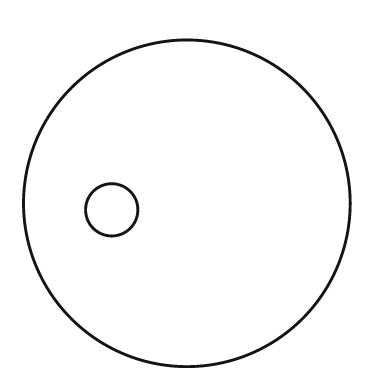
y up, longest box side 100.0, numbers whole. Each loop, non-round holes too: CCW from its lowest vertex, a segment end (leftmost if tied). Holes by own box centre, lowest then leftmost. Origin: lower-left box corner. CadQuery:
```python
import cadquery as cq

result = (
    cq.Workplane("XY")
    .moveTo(50.0, 50.0)
    .circle(50.0)
    .moveTo(27.0, 48.0)
    .circle(8.0)
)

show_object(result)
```